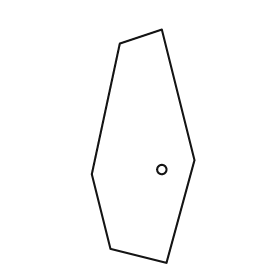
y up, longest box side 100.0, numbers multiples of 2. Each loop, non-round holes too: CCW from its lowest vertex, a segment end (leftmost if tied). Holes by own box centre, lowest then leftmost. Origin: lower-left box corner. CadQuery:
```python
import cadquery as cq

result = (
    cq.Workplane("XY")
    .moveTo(32.0, 0.0)
    .lineTo(44.0, 44.0)
    .lineTo(30.0, 100.0)
    .lineTo(12.0, 94.0)
    .lineTo(0.0, 38.0)
    .lineTo(8.0, 6.0)
    .close()
    .moveTo(30.0, 40.0)
    .circle(2.0)
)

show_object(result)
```